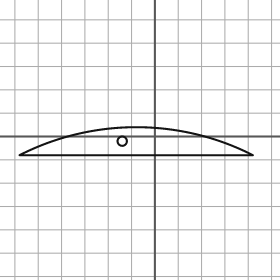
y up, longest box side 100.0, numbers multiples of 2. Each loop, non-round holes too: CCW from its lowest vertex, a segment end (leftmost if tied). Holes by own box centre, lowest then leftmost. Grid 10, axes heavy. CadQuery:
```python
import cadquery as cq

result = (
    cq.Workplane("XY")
    .moveTo(-58.0, -8.0)
    .lineTo(42.0, -8.0)
    .threePointArc((-8.0, 4.0), (-58.0, -8.0))
    .close()
    .moveTo(-14.0, -2.0)
    .circle(2.0)
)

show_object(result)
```